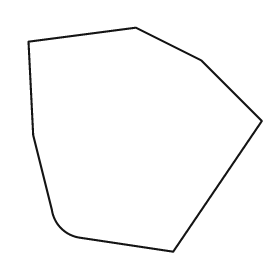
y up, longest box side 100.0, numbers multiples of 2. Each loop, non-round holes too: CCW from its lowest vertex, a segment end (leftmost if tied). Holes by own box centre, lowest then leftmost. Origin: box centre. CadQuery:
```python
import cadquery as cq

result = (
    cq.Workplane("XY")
    .moveTo(12.0, -48.0)
    .lineTo(50.0, 8.0)
    .lineTo(24.0, 34.0)
    .lineTo(-4.0, 48.0)
    .lineTo(-50.0, 42.0)
    .lineTo(-48.0, 2.0)
    .lineTo(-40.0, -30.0)
    .threePointArc((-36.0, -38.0), (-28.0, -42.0))
    .close()
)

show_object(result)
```